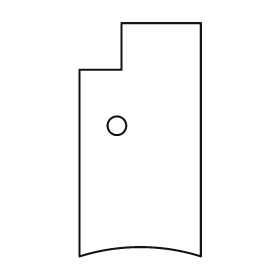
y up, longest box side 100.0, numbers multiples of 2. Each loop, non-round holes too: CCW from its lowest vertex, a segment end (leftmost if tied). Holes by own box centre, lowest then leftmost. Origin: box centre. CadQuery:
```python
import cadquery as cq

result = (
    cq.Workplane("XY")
    .moveTo(-26.0, -50.0)
    .threePointArc((0.0, -46.0), (26.0, -50.0))
    .lineTo(26.0, 50.0)
    .lineTo(-8.0, 50.0)
    .lineTo(-8.0, 30.0)
    .lineTo(-26.0, 30.0)
    .close()
    .moveTo(-10.0, 6.0)
    .circle(4.0)
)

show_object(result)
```